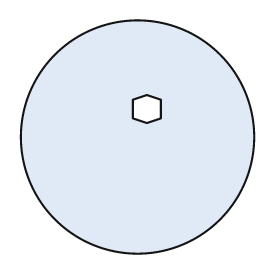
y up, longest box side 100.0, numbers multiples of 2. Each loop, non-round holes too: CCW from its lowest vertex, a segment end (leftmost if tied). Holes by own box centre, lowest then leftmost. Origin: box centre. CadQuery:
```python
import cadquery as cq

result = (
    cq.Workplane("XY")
    .moveTo(0.0, 0.0)
    .circle(50.0)
    .moveTo(4.0, 6.0)
    .lineTo(10.0, 8.0)
    .lineTo(10.0, 16.0)
    .lineTo(4.0, 18.0)
    .lineTo(-2.0, 16.0)
    .lineTo(-2.0, 8.0)
    .close()
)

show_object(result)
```